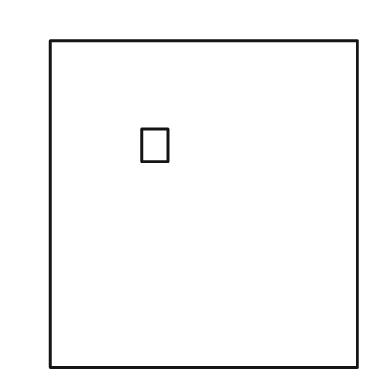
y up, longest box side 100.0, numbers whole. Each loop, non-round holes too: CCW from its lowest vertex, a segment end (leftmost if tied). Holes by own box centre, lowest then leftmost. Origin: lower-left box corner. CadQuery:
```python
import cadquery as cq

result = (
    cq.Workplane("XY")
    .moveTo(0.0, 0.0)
    .lineTo(94.0, 0.0)
    .lineTo(94.0, 100.0)
    .lineTo(0.0, 100.0)
    .close()
    .moveTo(28.0, 63.0)
    .lineTo(36.0, 63.0)
    .lineTo(36.0, 73.0)
    .lineTo(28.0, 73.0)
    .close()
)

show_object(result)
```